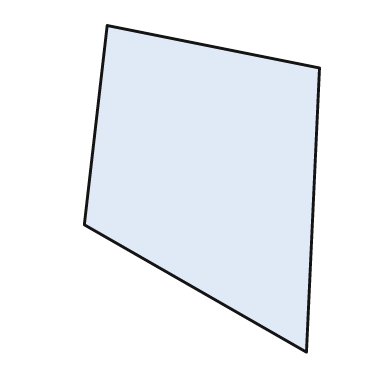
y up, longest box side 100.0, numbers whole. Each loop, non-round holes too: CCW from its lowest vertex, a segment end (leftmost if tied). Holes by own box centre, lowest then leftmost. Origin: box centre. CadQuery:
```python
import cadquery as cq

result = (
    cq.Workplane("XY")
    .moveTo(32.0, -50.0)
    .lineTo(36.0, 37.0)
    .lineTo(-29.0, 50.0)
    .lineTo(-36.0, -11.0)
    .close()
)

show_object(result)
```